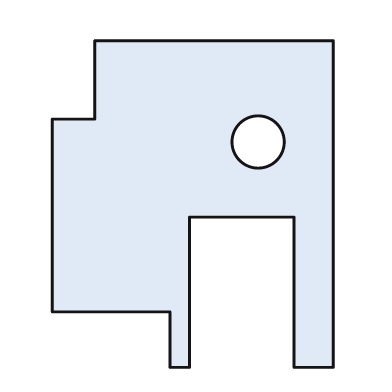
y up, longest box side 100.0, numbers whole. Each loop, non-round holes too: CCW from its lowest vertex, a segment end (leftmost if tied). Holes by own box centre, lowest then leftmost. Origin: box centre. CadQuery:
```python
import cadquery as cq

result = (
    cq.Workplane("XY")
    .moveTo(-7.0, -50.0)
    .lineTo(-1.0, -50.0)
    .lineTo(-1.0, -4.0)
    .lineTo(31.0, -4.0)
    .lineTo(31.0, -50.0)
    .lineTo(43.0, -50.0)
    .lineTo(43.0, 50.0)
    .lineTo(-30.0, 50.0)
    .lineTo(-30.0, 26.0)
    .lineTo(-43.0, 26.0)
    .lineTo(-43.0, -33.0)
    .lineTo(-7.0, -33.0)
    .close()
    .moveTo(20.0, 19.0)
    .circle(8.0)
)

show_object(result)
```